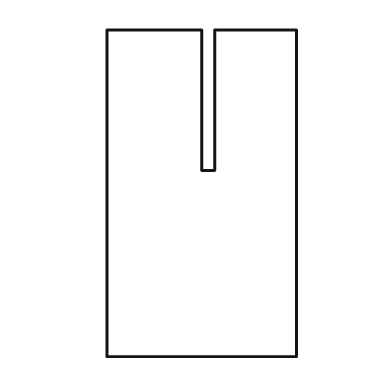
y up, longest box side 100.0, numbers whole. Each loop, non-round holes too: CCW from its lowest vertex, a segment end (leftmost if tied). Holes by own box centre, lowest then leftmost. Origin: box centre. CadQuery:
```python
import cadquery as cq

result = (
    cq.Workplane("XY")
    .moveTo(-29.0, -50.0)
    .lineTo(29.0, -50.0)
    .lineTo(29.0, 50.0)
    .lineTo(4.0, 50.0)
    .lineTo(4.0, 7.0)
    .lineTo(0.0, 7.0)
    .lineTo(0.0, 50.0)
    .lineTo(-29.0, 50.0)
    .close()
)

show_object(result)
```